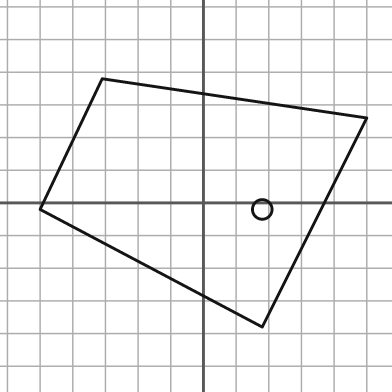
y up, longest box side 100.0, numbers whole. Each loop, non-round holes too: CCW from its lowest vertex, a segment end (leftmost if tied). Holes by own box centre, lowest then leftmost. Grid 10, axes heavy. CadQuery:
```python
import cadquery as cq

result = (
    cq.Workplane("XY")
    .moveTo(18.0, -38.0)
    .lineTo(50.0, 26.0)
    .lineTo(-31.0, 38.0)
    .lineTo(-50.0, -2.0)
    .close()
    .moveTo(18.0, -2.0)
    .circle(3.0)
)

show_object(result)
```